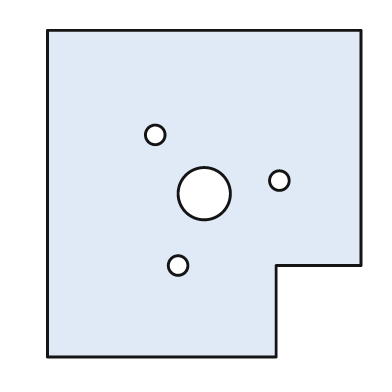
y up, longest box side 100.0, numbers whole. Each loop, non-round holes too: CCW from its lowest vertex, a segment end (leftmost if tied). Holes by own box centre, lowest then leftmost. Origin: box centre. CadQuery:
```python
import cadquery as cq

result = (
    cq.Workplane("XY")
    .moveTo(-48.0, -50.0)
    .lineTo(22.0, -50.0)
    .lineTo(22.0, -22.0)
    .lineTo(48.0, -22.0)
    .lineTo(48.0, 50.0)
    .lineTo(-48.0, 50.0)
    .close()
    .moveTo(-8.0, -22.0)
    .circle(3.0)
    .moveTo(0.0, 0.0)
    .circle(8.0)
    .moveTo(23.0, 4.0)
    .circle(3.0)
    .moveTo(-15.0, 18.0)
    .circle(3.0)
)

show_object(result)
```